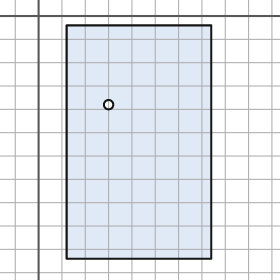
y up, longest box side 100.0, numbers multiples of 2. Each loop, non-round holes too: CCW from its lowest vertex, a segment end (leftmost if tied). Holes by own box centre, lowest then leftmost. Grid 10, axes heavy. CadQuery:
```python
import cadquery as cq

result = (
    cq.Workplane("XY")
    .moveTo(12.0, -104.0)
    .lineTo(74.0, -104.0)
    .lineTo(74.0, -4.0)
    .lineTo(12.0, -4.0)
    .close()
    .moveTo(30.0, -38.0)
    .circle(2.0)
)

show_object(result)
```